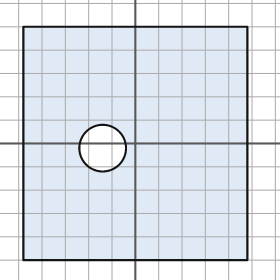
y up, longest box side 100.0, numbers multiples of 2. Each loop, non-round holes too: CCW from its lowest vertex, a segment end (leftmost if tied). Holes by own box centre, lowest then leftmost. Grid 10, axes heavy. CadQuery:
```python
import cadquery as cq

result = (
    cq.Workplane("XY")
    .moveTo(-48.0, -50.0)
    .lineTo(48.0, -50.0)
    .lineTo(48.0, 50.0)
    .lineTo(-48.0, 50.0)
    .close()
    .moveTo(-14.0, -2.0)
    .circle(10.0)
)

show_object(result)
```